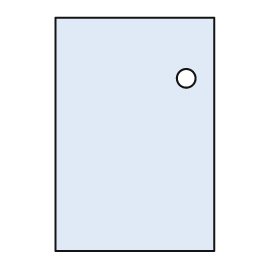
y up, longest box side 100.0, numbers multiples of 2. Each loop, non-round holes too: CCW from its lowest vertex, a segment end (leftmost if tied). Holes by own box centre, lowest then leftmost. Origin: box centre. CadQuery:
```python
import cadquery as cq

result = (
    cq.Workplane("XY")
    .moveTo(-34.0, -50.0)
    .lineTo(34.0, -50.0)
    .lineTo(34.0, 50.0)
    .lineTo(-34.0, 50.0)
    .close()
    .moveTo(22.0, 24.0)
    .circle(4.0)
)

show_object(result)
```